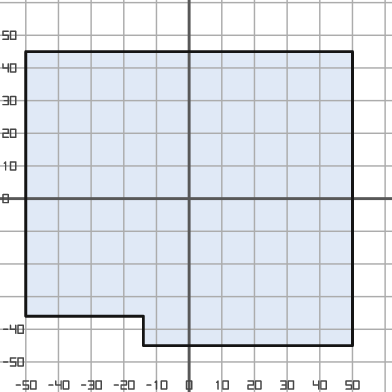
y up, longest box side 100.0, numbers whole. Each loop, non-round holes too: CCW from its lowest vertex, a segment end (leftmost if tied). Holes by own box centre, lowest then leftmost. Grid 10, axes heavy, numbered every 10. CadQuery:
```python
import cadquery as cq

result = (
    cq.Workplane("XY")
    .moveTo(-14.0, -45.0)
    .lineTo(50.0, -45.0)
    .lineTo(50.0, 45.0)
    .lineTo(-50.0, 45.0)
    .lineTo(-50.0, -36.0)
    .lineTo(-14.0, -36.0)
    .close()
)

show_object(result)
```